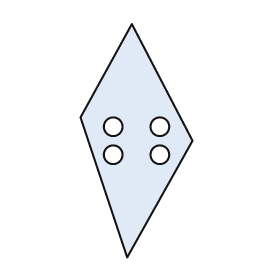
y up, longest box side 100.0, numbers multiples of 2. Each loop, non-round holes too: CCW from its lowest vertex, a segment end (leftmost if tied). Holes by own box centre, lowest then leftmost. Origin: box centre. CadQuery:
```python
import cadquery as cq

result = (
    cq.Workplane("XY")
    .moveTo(-4.0, -50.0)
    .lineTo(24.0, 0.0)
    .lineTo(-2.0, 50.0)
    .lineTo(-24.0, 10.0)
    .close()
    .moveTo(-10.0, -6.0)
    .circle(4.0)
    .moveTo(10.0, -6.0)
    .circle(4.0)
    .moveTo(-10.0, 6.0)
    .circle(4.0)
    .moveTo(10.0, 6.0)
    .circle(4.0)
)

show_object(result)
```